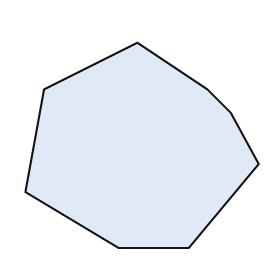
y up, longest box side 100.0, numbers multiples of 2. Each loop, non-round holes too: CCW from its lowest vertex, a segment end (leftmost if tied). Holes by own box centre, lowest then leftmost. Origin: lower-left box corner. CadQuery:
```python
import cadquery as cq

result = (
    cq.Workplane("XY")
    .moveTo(40.0, 0.0)
    .lineTo(70.0, 0.0)
    .lineTo(100.0, 36.0)
    .lineTo(88.0, 58.0)
    .lineTo(78.0, 68.0)
    .lineTo(48.0, 88.0)
    .lineTo(8.0, 68.0)
    .lineTo(0.0, 24.0)
    .close()
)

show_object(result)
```